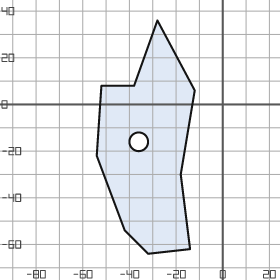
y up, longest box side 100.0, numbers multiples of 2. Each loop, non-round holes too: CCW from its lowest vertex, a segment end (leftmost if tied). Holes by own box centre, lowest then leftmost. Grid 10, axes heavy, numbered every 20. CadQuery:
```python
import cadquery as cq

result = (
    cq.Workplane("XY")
    .moveTo(-32.0, -64.0)
    .lineTo(-14.0, -62.0)
    .lineTo(-18.0, -30.0)
    .lineTo(-12.0, 6.0)
    .lineTo(-28.0, 36.0)
    .lineTo(-38.0, 8.0)
    .lineTo(-52.0, 8.0)
    .lineTo(-54.0, -22.0)
    .lineTo(-42.0, -54.0)
    .close()
    .moveTo(-36.0, -16.0)
    .circle(4.0)
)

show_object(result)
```